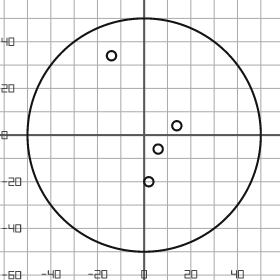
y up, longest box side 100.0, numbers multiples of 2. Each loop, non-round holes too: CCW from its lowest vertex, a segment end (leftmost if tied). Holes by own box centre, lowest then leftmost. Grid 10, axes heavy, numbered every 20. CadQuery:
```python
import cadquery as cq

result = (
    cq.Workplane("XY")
    .moveTo(0.0, 0.0)
    .circle(50.0)
    .moveTo(2.0, -20.0)
    .circle(2.0)
    .moveTo(6.0, -6.0)
    .circle(2.0)
    .moveTo(14.0, 4.0)
    .circle(2.0)
    .moveTo(-14.0, 34.0)
    .circle(2.0)
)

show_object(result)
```